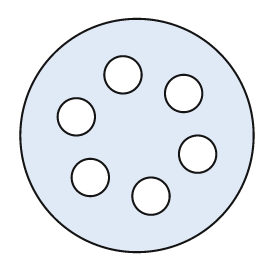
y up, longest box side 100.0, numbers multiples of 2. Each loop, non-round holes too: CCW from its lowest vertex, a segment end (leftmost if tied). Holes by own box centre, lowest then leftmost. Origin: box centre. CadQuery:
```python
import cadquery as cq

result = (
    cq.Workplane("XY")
    .moveTo(0.0, 0.0)
    .circle(50.0)
    .moveTo(6.0, -26.0)
    .circle(8.0)
    .moveTo(-20.0, -18.0)
    .circle(8.0)
    .moveTo(26.0, -8.0)
    .circle(8.0)
    .moveTo(-26.0, 8.0)
    .circle(8.0)
    .moveTo(20.0, 18.0)
    .circle(8.0)
    .moveTo(-6.0, 26.0)
    .circle(8.0)
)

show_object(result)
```